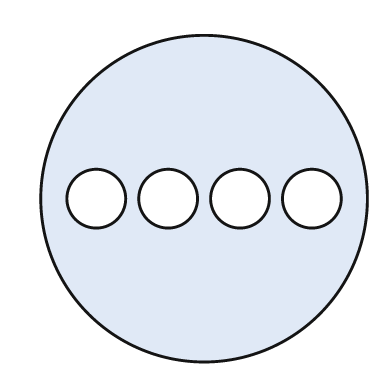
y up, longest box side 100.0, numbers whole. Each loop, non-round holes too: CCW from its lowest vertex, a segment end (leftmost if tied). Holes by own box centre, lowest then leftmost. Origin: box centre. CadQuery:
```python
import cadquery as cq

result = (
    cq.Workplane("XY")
    .moveTo(0.0, 0.0)
    .circle(50.0)
    .moveTo(-33.0, 0.0)
    .circle(9.0)
    .moveTo(-11.0, 0.0)
    .circle(9.0)
    .moveTo(11.0, 0.0)
    .circle(9.0)
    .moveTo(33.0, 0.0)
    .circle(9.0)
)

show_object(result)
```